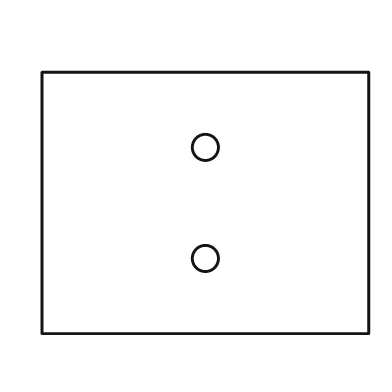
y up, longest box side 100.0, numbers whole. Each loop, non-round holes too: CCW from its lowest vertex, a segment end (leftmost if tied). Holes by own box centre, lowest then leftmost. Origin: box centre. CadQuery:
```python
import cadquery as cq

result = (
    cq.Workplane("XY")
    .moveTo(-50.0, -40.0)
    .lineTo(50.0, -40.0)
    .lineTo(50.0, 40.0)
    .lineTo(-50.0, 40.0)
    .close()
    .moveTo(0.0, -17.0)
    .circle(4.0)
    .moveTo(0.0, 17.0)
    .circle(4.0)
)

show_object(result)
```